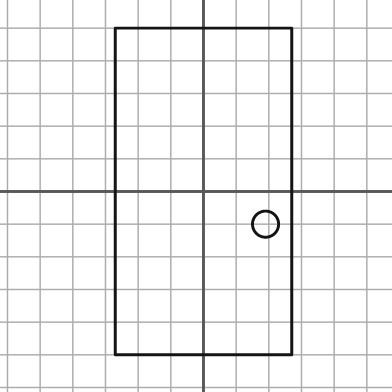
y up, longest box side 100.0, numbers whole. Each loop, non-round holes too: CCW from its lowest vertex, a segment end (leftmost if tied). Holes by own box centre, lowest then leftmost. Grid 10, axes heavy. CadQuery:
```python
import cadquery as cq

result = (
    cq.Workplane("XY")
    .moveTo(-27.0, -50.0)
    .lineTo(27.0, -50.0)
    .lineTo(27.0, 50.0)
    .lineTo(-27.0, 50.0)
    .close()
    .moveTo(19.0, -10.0)
    .circle(4.0)
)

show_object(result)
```